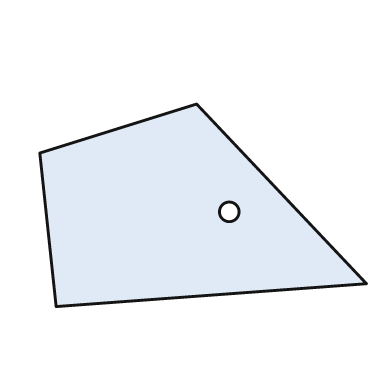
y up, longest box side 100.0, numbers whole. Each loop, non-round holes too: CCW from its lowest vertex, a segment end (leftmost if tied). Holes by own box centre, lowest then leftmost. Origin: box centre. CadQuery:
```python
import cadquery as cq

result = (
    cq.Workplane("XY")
    .moveTo(-45.0, -31.0)
    .lineTo(50.0, -24.0)
    .lineTo(-2.0, 31.0)
    .lineTo(-50.0, 16.0)
    .close()
    .moveTo(8.0, -2.0)
    .circle(3.0)
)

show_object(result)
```